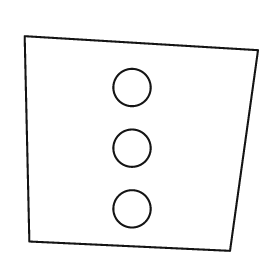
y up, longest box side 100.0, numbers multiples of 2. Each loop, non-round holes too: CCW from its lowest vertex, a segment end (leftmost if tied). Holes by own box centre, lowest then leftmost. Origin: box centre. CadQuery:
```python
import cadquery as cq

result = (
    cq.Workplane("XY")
    .moveTo(38.0, -46.0)
    .lineTo(50.0, 40.0)
    .lineTo(-50.0, 46.0)
    .lineTo(-48.0, -42.0)
    .close()
    .moveTo(-4.0, -28.0)
    .circle(8.0)
    .moveTo(-4.0, -2.0)
    .circle(8.0)
    .moveTo(-4.0, 24.0)
    .circle(8.0)
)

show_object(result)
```